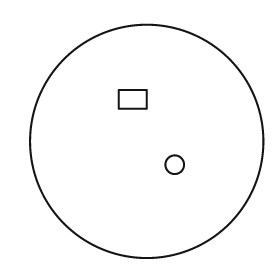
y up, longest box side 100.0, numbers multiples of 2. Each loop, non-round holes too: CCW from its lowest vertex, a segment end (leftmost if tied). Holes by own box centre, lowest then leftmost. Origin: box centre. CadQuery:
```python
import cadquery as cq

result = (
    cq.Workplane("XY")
    .moveTo(0.0, 0.0)
    .circle(50.0)
    .moveTo(12.0, -10.0)
    .circle(4.0)
    .moveTo(-12.0, 14.0)
    .lineTo(0.0, 14.0)
    .lineTo(0.0, 22.0)
    .lineTo(-12.0, 22.0)
    .close()
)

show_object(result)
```